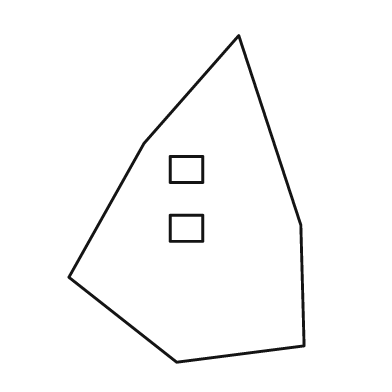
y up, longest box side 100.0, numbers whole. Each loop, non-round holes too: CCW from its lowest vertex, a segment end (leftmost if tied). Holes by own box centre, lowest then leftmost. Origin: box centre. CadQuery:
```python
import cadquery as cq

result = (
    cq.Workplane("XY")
    .moveTo(-3.0, -50.0)
    .lineTo(36.0, -45.0)
    .lineTo(35.0, -8.0)
    .lineTo(16.0, 50.0)
    .lineTo(-13.0, 17.0)
    .lineTo(-36.0, -24.0)
    .close()
    .moveTo(-5.0, -13.0)
    .lineTo(5.0, -13.0)
    .lineTo(5.0, -5.0)
    .lineTo(-5.0, -5.0)
    .close()
    .moveTo(-5.0, 5.0)
    .lineTo(5.0, 5.0)
    .lineTo(5.0, 13.0)
    .lineTo(-5.0, 13.0)
    .close()
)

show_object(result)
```